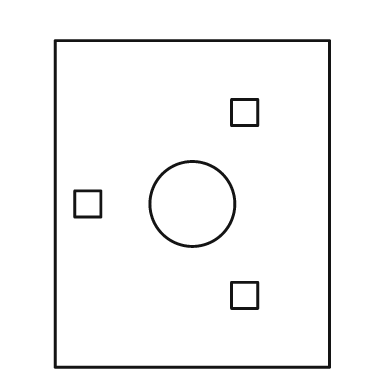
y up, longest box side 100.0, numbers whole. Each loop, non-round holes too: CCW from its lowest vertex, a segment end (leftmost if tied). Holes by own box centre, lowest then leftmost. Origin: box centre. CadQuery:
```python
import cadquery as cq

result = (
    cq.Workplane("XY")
    .moveTo(-42.0, -50.0)
    .lineTo(42.0, -50.0)
    .lineTo(42.0, 50.0)
    .lineTo(-42.0, 50.0)
    .close()
    .moveTo(12.0, -32.0)
    .lineTo(20.0, -32.0)
    .lineTo(20.0, -24.0)
    .lineTo(12.0, -24.0)
    .close()
    .moveTo(-36.0, -4.0)
    .lineTo(-28.0, -4.0)
    .lineTo(-28.0, 4.0)
    .lineTo(-36.0, 4.0)
    .close()
    .moveTo(0.0, 0.0)
    .circle(13.0)
    .moveTo(12.0, 24.0)
    .lineTo(20.0, 24.0)
    .lineTo(20.0, 32.0)
    .lineTo(12.0, 32.0)
    .close()
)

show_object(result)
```